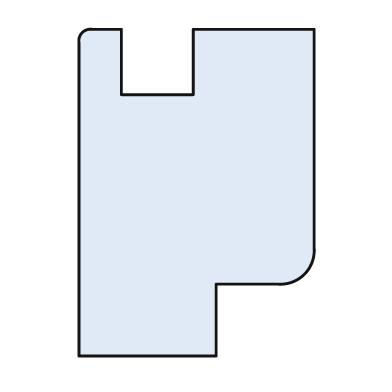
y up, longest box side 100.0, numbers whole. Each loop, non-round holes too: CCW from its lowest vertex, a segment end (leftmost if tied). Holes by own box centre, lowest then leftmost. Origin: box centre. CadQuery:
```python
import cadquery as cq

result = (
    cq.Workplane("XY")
    .moveTo(-36.0, -50.0)
    .lineTo(6.0, -50.0)
    .lineTo(6.0, -28.0)
    .lineTo(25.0, -28.0)
    .threePointArc((33.0, -25.0), (36.0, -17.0))
    .lineTo(36.0, 50.0)
    .lineTo(-1.0, 50.0)
    .lineTo(-1.0, 30.0)
    .lineTo(-23.0, 30.0)
    .lineTo(-23.0, 50.0)
    .lineTo(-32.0, 50.0)
    .threePointArc((-35.0, 49.0), (-36.0, 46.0))
    .close()
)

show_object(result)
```